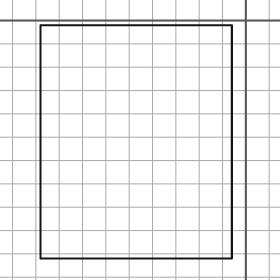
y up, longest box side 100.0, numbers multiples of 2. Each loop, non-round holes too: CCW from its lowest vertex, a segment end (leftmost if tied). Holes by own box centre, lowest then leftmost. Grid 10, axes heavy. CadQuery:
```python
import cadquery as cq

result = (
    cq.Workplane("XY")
    .moveTo(-88.0, -102.0)
    .lineTo(-6.0, -102.0)
    .lineTo(-6.0, -2.0)
    .lineTo(-88.0, -2.0)
    .close()
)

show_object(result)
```